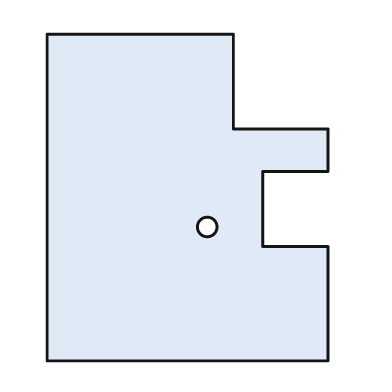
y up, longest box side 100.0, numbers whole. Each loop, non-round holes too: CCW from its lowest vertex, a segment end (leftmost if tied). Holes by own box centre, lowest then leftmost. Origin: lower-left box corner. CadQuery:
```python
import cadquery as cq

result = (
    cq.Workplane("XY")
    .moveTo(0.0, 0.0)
    .lineTo(86.0, 0.0)
    .lineTo(86.0, 35.0)
    .lineTo(66.0, 35.0)
    .lineTo(66.0, 58.0)
    .lineTo(86.0, 58.0)
    .lineTo(86.0, 71.0)
    .lineTo(57.0, 71.0)
    .lineTo(57.0, 100.0)
    .lineTo(0.0, 100.0)
    .close()
    .moveTo(49.0, 41.0)
    .circle(3.0)
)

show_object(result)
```